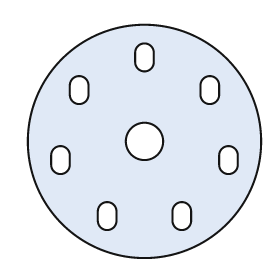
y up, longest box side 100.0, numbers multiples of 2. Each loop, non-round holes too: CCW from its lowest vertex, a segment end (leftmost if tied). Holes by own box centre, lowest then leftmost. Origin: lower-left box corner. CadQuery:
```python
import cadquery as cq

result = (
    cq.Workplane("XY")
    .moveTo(50.0, 50.0)
    .circle(50.0)
    .moveTo(30.0, 16.0)
    .threePointArc((34.0, 12.0), (38.0, 16.0))
    .lineTo(38.0, 20.0)
    .threePointArc((34.0, 24.0), (30.0, 20.0))
    .close()
    .moveTo(62.0, 16.0)
    .threePointArc((66.0, 12.0), (70.0, 16.0))
    .lineTo(70.0, 20.0)
    .threePointArc((66.0, 24.0), (62.0, 20.0))
    .close()
    .moveTo(10.0, 40.0)
    .threePointArc((14.0, 36.0), (18.0, 40.0))
    .lineTo(18.0, 44.0)
    .threePointArc((14.0, 48.0), (10.0, 44.0))
    .close()
    .moveTo(82.0, 40.0)
    .threePointArc((86.0, 36.0), (90.0, 40.0))
    .lineTo(90.0, 44.0)
    .threePointArc((86.0, 48.0), (82.0, 44.0))
    .close()
    .moveTo(50.0, 50.0)
    .circle(8.0)
    .moveTo(18.0, 70.0)
    .threePointArc((22.0, 66.0), (26.0, 70.0))
    .lineTo(26.0, 74.0)
    .threePointArc((22.0, 78.0), (18.0, 74.0))
    .close()
    .moveTo(74.0, 70.0)
    .threePointArc((78.0, 66.0), (82.0, 70.0))
    .lineTo(82.0, 74.0)
    .threePointArc((78.0, 78.0), (74.0, 74.0))
    .close()
    .moveTo(46.0, 84.0)
    .threePointArc((50.0, 80.0), (54.0, 84.0))
    .lineTo(54.0, 88.0)
    .threePointArc((50.0, 92.0), (46.0, 88.0))
    .close()
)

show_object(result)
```